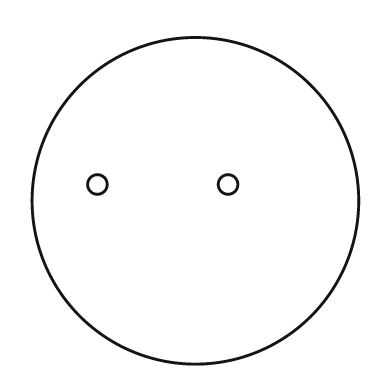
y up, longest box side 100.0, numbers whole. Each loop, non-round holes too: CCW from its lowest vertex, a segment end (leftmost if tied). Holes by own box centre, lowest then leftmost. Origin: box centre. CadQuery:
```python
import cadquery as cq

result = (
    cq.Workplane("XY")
    .moveTo(0.0, 0.0)
    .circle(50.0)
    .moveTo(-30.0, 5.0)
    .circle(3.0)
    .moveTo(10.0, 5.0)
    .circle(3.0)
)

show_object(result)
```